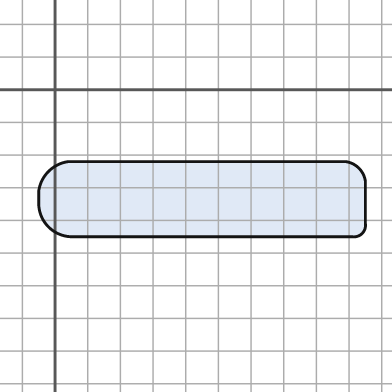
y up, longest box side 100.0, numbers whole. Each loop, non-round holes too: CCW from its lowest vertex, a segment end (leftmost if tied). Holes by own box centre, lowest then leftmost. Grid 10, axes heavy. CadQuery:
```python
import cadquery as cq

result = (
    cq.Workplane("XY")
    .moveTo(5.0, -45.0)
    .lineTo(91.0, -45.0)
    .threePointArc((94.0, -44.0), (95.0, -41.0))
    .lineTo(95.0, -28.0)
    .threePointArc((93.0, -24.0), (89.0, -22.0))
    .lineTo(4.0, -22.0)
    .threePointArc((-2.0, -25.0), (-5.0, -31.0))
    .lineTo(-5.0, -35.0)
    .threePointArc((-2.0, -42.0), (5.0, -45.0))
    .close()
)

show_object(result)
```